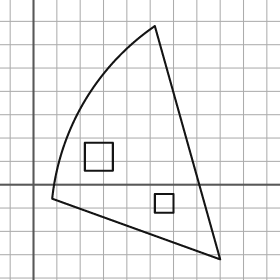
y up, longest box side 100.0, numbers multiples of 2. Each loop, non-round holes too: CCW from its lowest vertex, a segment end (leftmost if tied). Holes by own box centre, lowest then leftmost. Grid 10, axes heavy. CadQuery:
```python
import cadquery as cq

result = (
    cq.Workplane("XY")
    .moveTo(80.0, -32.0)
    .lineTo(52.0, 68.0)
    .threePointArc((22.0, 36.0), (8.0, -6.0))
    .close()
    .moveTo(52.0, -12.0)
    .lineTo(60.0, -12.0)
    .lineTo(60.0, -4.0)
    .lineTo(52.0, -4.0)
    .close()
    .moveTo(22.0, 6.0)
    .lineTo(34.0, 6.0)
    .lineTo(34.0, 18.0)
    .lineTo(22.0, 18.0)
    .close()
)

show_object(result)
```